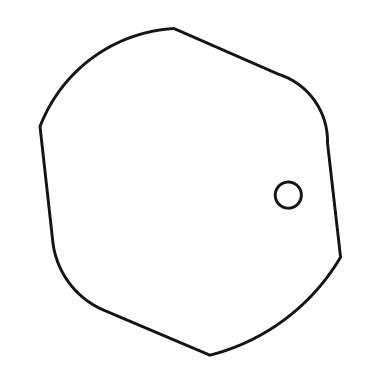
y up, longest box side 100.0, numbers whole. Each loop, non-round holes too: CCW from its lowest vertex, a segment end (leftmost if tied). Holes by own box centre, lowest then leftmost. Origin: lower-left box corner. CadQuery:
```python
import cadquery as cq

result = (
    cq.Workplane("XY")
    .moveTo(52.0, 0.0)
    .threePointArc((75.0, 11.0), (92.0, 30.0))
    .lineTo(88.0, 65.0)
    .threePointArc((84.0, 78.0), (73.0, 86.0))
    .lineTo(41.0, 100.0)
    .threePointArc((16.0, 91.0), (0.0, 70.0))
    .lineTo(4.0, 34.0)
    .threePointArc((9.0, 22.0), (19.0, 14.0))
    .close()
    .moveTo(76.0, 49.0)
    .circle(4.0)
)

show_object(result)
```